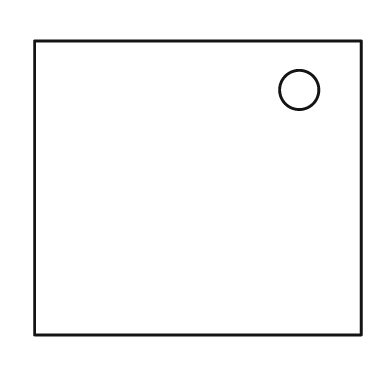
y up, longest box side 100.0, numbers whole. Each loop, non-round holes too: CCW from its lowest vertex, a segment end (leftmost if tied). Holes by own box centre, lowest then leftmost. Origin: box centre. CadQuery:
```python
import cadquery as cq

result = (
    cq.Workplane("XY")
    .moveTo(-50.0, -45.0)
    .lineTo(50.0, -45.0)
    .lineTo(50.0, 45.0)
    .lineTo(-50.0, 45.0)
    .close()
    .moveTo(31.0, 30.0)
    .circle(6.0)
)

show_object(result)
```